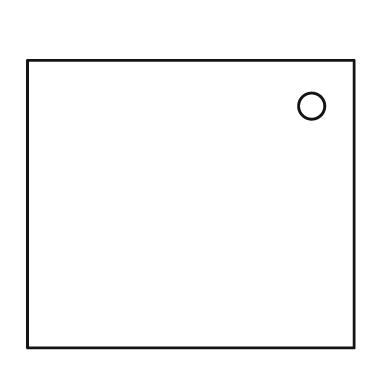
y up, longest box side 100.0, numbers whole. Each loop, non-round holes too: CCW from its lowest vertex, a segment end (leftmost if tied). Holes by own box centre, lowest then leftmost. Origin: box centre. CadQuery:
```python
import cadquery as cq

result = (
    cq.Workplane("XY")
    .moveTo(-50.0, -44.0)
    .lineTo(50.0, -44.0)
    .lineTo(50.0, 44.0)
    .lineTo(-50.0, 44.0)
    .close()
    .moveTo(37.0, 30.0)
    .circle(4.0)
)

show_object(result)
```